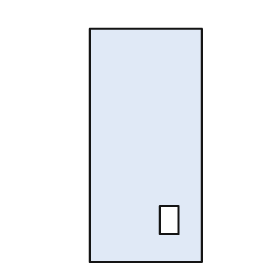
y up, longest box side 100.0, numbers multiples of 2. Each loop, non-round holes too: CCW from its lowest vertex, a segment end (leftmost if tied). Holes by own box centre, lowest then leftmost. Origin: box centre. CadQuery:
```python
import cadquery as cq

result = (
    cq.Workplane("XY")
    .moveTo(-24.0, -50.0)
    .lineTo(24.0, -50.0)
    .lineTo(24.0, 50.0)
    .lineTo(-24.0, 50.0)
    .close()
    .moveTo(6.0, -38.0)
    .lineTo(14.0, -38.0)
    .lineTo(14.0, -26.0)
    .lineTo(6.0, -26.0)
    .close()
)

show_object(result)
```